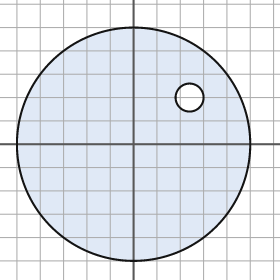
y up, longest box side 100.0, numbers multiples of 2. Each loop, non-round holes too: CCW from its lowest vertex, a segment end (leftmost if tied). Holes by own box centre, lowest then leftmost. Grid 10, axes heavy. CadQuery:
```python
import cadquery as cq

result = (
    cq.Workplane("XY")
    .moveTo(0.0, 0.0)
    .circle(50.0)
    .moveTo(24.0, 20.0)
    .circle(6.0)
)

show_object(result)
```